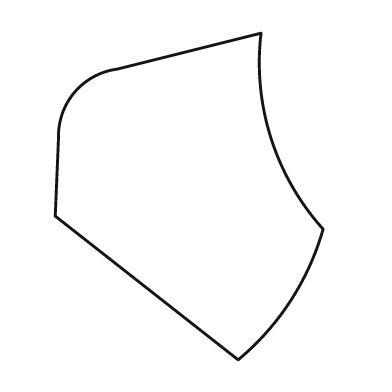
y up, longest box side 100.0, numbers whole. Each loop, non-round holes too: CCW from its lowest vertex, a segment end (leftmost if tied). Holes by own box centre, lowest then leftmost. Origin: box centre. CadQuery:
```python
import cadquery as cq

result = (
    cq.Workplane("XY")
    .moveTo(15.0, -50.0)
    .threePointArc((31.0, -32.0), (41.0, -10.0))
    .threePointArc((25.0, 18.0), (22.0, 50.0))
    .lineTo(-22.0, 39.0)
    .threePointArc((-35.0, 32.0), (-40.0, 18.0))
    .lineTo(-41.0, -6.0)
    .close()
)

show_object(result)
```